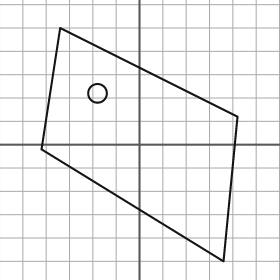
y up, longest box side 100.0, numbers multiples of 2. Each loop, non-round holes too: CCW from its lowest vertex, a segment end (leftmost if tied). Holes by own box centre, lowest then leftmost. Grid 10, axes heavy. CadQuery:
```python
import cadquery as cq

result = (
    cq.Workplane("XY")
    .moveTo(36.0, -50.0)
    .lineTo(42.0, 12.0)
    .lineTo(-34.0, 50.0)
    .lineTo(-42.0, -2.0)
    .close()
    .moveTo(-18.0, 22.0)
    .circle(4.0)
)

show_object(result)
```